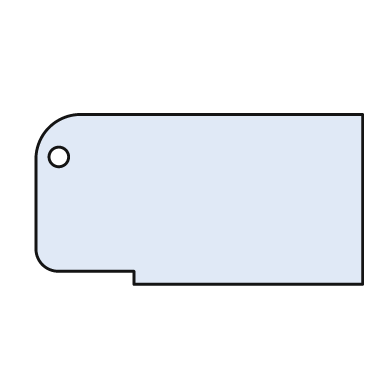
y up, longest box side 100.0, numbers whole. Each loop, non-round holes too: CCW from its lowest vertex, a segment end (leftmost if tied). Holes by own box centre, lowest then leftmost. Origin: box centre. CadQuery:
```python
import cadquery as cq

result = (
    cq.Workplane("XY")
    .moveTo(-20.0, -26.0)
    .lineTo(50.0, -26.0)
    .lineTo(50.0, 26.0)
    .lineTo(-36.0, 26.0)
    .threePointArc((-46.0, 22.0), (-50.0, 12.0))
    .lineTo(-50.0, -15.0)
    .threePointArc((-48.0, -20.0), (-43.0, -22.0))
    .lineTo(-20.0, -22.0)
    .close()
    .moveTo(-43.0, 13.0)
    .circle(3.0)
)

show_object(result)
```